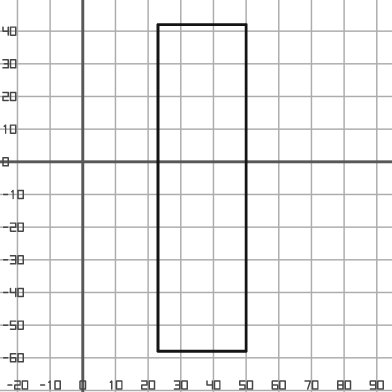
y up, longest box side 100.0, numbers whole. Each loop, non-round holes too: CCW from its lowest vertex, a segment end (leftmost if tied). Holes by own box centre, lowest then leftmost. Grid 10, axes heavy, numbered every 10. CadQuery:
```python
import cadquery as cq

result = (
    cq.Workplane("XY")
    .moveTo(23.0, -58.0)
    .lineTo(50.0, -58.0)
    .lineTo(50.0, 42.0)
    .lineTo(23.0, 42.0)
    .close()
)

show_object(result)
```